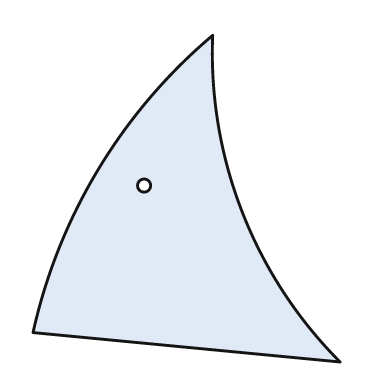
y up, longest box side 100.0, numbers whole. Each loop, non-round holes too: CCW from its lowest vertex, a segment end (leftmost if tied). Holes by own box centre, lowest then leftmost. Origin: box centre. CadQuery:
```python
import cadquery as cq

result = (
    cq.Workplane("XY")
    .moveTo(47.0, -50.0)
    .threePointArc((17.0, -4.0), (8.0, 50.0))
    .threePointArc((-27.0, 9.0), (-47.0, -41.0))
    .close()
    .moveTo(-13.0, 4.0)
    .circle(2.0)
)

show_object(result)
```